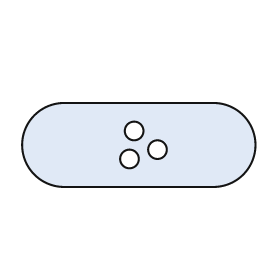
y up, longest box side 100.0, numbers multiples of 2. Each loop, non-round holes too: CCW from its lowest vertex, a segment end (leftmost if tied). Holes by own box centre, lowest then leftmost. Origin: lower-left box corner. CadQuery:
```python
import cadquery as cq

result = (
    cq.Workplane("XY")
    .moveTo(18.0, 0.0)
    .lineTo(82.0, 0.0)
    .threePointArc((100.0, 18.0), (82.0, 36.0))
    .lineTo(18.0, 36.0)
    .threePointArc((0.0, 18.0), (18.0, 0.0))
    .close()
    .moveTo(46.0, 12.0)
    .circle(4.0)
    .moveTo(58.0, 16.0)
    .circle(4.0)
    .moveTo(48.0, 24.0)
    .circle(4.0)
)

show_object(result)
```